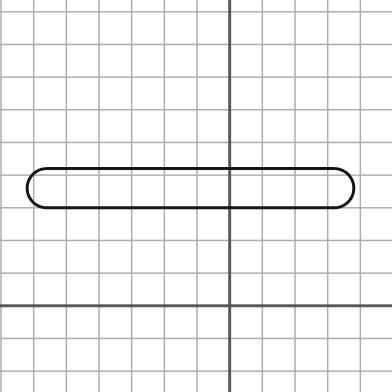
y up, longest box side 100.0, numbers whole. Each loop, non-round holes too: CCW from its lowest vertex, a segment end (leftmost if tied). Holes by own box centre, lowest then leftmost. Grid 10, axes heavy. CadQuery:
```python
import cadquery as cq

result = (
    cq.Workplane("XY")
    .moveTo(-56.0, 30.0)
    .lineTo(32.0, 30.0)
    .threePointArc((38.0, 36.0), (32.0, 42.0))
    .lineTo(-56.0, 42.0)
    .threePointArc((-62.0, 36.0), (-56.0, 30.0))
    .close()
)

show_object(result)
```